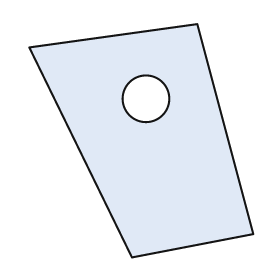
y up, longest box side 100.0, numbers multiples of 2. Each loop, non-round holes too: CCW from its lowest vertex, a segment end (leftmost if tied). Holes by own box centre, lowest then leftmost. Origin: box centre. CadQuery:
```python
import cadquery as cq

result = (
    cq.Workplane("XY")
    .moveTo(-4.0, -50.0)
    .lineTo(48.0, -40.0)
    .lineTo(24.0, 50.0)
    .lineTo(-48.0, 40.0)
    .close()
    .moveTo(2.0, 18.0)
    .circle(10.0)
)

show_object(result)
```